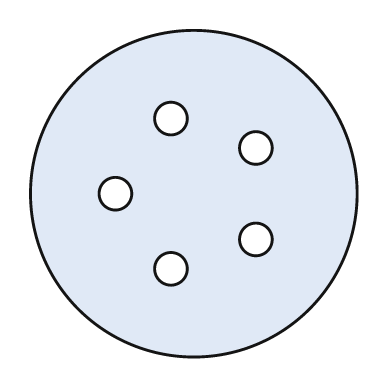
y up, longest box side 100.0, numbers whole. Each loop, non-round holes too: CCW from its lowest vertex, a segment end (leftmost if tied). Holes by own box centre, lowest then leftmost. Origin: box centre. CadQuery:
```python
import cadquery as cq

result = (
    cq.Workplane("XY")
    .moveTo(0.0, 0.0)
    .circle(50.0)
    .moveTo(-7.0, -23.0)
    .circle(5.0)
    .moveTo(19.0, -14.0)
    .circle(5.0)
    .moveTo(-24.0, 0.0)
    .circle(5.0)
    .moveTo(19.0, 14.0)
    .circle(5.0)
    .moveTo(-7.0, 23.0)
    .circle(5.0)
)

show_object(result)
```